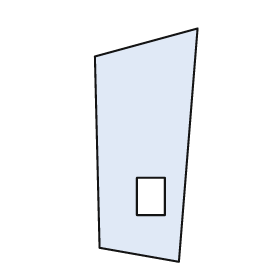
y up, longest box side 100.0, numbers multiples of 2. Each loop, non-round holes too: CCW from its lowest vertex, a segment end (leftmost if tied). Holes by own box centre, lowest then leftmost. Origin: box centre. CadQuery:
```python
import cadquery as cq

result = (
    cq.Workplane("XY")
    .moveTo(14.0, -50.0)
    .lineTo(22.0, 50.0)
    .lineTo(-22.0, 38.0)
    .lineTo(-20.0, -44.0)
    .close()
    .moveTo(-4.0, -30.0)
    .lineTo(8.0, -30.0)
    .lineTo(8.0, -14.0)
    .lineTo(-4.0, -14.0)
    .close()
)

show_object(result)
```